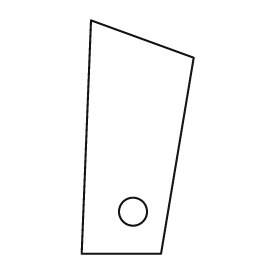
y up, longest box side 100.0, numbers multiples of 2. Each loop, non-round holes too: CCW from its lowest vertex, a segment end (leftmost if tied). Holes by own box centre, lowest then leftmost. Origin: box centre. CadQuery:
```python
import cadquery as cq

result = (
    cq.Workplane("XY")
    .moveTo(-24.0, -50.0)
    .lineTo(10.0, -50.0)
    .lineTo(24.0, 34.0)
    .lineTo(-20.0, 50.0)
    .close()
    .moveTo(-2.0, -32.0)
    .circle(6.0)
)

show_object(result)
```